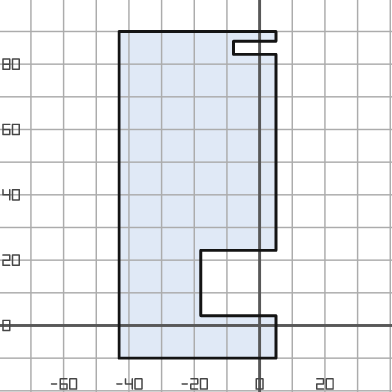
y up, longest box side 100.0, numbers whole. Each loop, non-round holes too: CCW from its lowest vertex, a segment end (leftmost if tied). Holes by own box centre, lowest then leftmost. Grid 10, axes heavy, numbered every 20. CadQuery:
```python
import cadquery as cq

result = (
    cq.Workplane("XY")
    .moveTo(-43.0, -10.0)
    .lineTo(5.0, -10.0)
    .lineTo(5.0, 3.0)
    .lineTo(-18.0, 3.0)
    .lineTo(-18.0, 23.0)
    .lineTo(5.0, 23.0)
    .lineTo(5.0, 83.0)
    .lineTo(-8.0, 83.0)
    .lineTo(-8.0, 87.0)
    .lineTo(5.0, 87.0)
    .lineTo(5.0, 90.0)
    .lineTo(-43.0, 90.0)
    .close()
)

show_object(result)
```